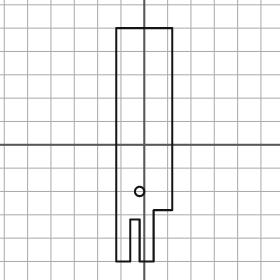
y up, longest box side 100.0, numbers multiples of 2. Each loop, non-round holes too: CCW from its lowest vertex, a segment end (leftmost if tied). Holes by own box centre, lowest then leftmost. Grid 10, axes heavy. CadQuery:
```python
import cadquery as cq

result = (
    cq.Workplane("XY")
    .moveTo(-12.0, -50.0)
    .lineTo(-6.0, -50.0)
    .lineTo(-6.0, -32.0)
    .lineTo(-2.0, -32.0)
    .lineTo(-2.0, -50.0)
    .lineTo(4.0, -50.0)
    .lineTo(4.0, -28.0)
    .lineTo(12.0, -28.0)
    .lineTo(12.0, 50.0)
    .lineTo(-12.0, 50.0)
    .close()
    .moveTo(-2.0, -20.0)
    .circle(2.0)
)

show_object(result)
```